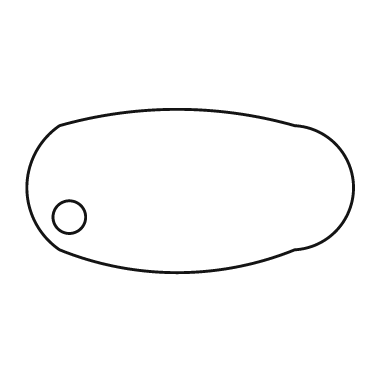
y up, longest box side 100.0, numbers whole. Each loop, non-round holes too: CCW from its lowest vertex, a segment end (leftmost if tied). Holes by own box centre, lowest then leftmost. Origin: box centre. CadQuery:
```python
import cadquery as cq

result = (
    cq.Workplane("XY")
    .moveTo(-40.0, -18.0)
    .threePointArc((-4.0, -25.0), (32.0, -18.0))
    .threePointArc((50.0, 1.0), (32.0, 20.0))
    .threePointArc((-4.0, 25.0), (-40.0, 20.0))
    .threePointArc((-50.0, 1.0), (-40.0, -18.0))
    .close()
    .moveTo(-37.0, -8.0)
    .circle(5.0)
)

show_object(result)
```